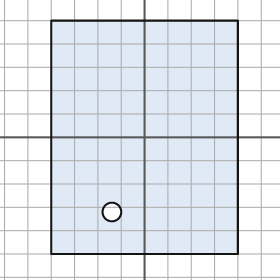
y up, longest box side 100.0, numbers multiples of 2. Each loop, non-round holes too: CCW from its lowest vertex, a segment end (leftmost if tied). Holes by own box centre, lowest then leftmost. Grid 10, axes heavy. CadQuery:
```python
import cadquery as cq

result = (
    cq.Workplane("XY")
    .moveTo(-40.0, -50.0)
    .lineTo(40.0, -50.0)
    .lineTo(40.0, 50.0)
    .lineTo(-40.0, 50.0)
    .close()
    .moveTo(-14.0, -32.0)
    .circle(4.0)
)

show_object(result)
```